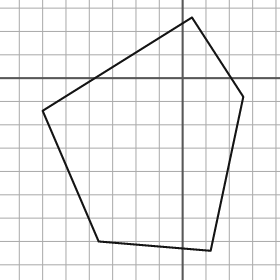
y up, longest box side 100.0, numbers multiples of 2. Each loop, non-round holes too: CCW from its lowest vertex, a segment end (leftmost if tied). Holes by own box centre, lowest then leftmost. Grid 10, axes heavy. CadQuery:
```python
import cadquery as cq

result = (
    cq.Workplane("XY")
    .moveTo(12.0, -74.0)
    .lineTo(26.0, -8.0)
    .lineTo(4.0, 26.0)
    .lineTo(-60.0, -14.0)
    .lineTo(-36.0, -70.0)
    .close()
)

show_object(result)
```